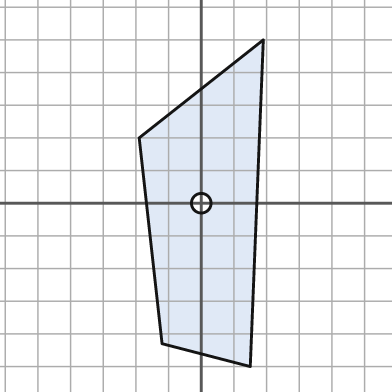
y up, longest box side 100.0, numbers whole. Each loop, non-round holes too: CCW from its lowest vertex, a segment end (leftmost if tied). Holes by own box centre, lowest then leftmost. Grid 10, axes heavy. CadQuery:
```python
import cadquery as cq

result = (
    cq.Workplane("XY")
    .moveTo(15.0, -50.0)
    .lineTo(19.0, 50.0)
    .lineTo(-19.0, 20.0)
    .lineTo(-12.0, -43.0)
    .close()
    .moveTo(0.0, 0.0)
    .circle(3.0)
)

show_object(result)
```